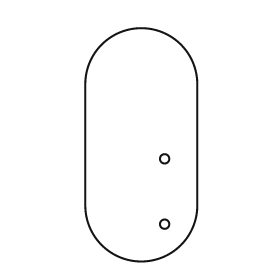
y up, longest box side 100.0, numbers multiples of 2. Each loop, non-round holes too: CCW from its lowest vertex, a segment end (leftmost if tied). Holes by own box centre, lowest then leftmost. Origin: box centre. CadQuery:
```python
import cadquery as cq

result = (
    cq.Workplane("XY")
    .moveTo(-24.0, -26.0)
    .threePointArc((0.0, -50.0), (24.0, -26.0))
    .lineTo(24.0, 26.0)
    .threePointArc((0.0, 50.0), (-24.0, 26.0))
    .close()
    .moveTo(10.0, -34.0)
    .circle(2.0)
    .moveTo(10.0, -6.0)
    .circle(2.0)
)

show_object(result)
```